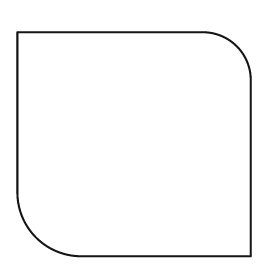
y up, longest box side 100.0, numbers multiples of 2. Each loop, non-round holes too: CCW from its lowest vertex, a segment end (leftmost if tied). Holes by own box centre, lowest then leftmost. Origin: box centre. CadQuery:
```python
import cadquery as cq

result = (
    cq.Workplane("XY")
    .moveTo(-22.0, -48.0)
    .lineTo(50.0, -48.0)
    .lineTo(50.0, 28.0)
    .threePointArc((44.0, 42.0), (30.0, 48.0))
    .lineTo(-50.0, 48.0)
    .lineTo(-50.0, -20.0)
    .threePointArc((-42.0, -40.0), (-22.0, -48.0))
    .close()
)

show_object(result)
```